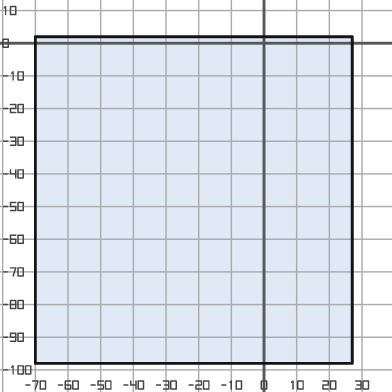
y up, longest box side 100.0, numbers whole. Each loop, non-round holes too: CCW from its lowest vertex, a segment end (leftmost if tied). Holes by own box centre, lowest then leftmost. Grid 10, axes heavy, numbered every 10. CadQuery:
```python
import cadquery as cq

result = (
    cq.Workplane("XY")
    .moveTo(-70.0, -98.0)
    .lineTo(27.0, -98.0)
    .lineTo(27.0, 2.0)
    .lineTo(-70.0, 2.0)
    .close()
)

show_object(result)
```